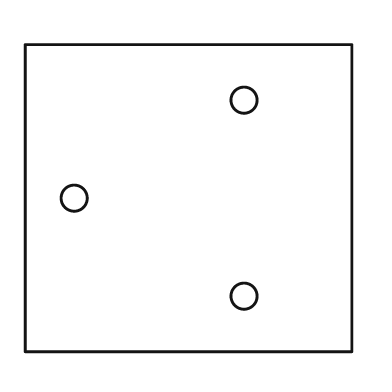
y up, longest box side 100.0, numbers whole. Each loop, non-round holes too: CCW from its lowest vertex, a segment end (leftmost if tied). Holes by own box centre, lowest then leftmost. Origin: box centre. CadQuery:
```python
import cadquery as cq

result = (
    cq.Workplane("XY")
    .moveTo(-50.0, -47.0)
    .lineTo(50.0, -47.0)
    .lineTo(50.0, 47.0)
    .lineTo(-50.0, 47.0)
    .close()
    .moveTo(17.0, -30.0)
    .circle(4.0)
    .moveTo(-35.0, 0.0)
    .circle(4.0)
    .moveTo(17.0, 30.0)
    .circle(4.0)
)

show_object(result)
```